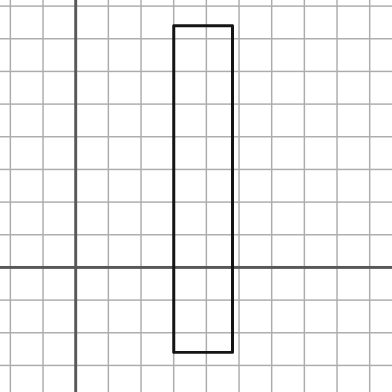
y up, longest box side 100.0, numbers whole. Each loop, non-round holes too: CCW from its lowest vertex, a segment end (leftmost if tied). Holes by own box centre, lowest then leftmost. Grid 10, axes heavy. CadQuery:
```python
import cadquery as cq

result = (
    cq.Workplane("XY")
    .moveTo(30.0, -26.0)
    .lineTo(48.0, -26.0)
    .lineTo(48.0, 74.0)
    .lineTo(30.0, 74.0)
    .close()
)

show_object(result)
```